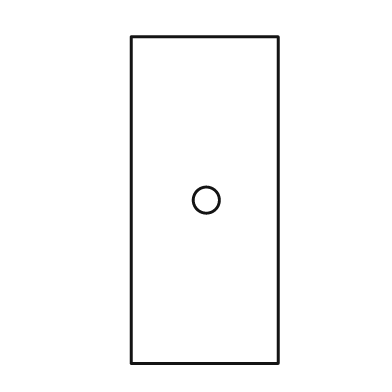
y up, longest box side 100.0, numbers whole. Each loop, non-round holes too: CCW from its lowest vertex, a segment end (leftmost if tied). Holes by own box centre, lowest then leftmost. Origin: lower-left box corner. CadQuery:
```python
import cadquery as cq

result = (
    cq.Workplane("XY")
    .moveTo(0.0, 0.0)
    .lineTo(45.0, 0.0)
    .lineTo(45.0, 100.0)
    .lineTo(0.0, 100.0)
    .close()
    .moveTo(23.0, 50.0)
    .circle(4.0)
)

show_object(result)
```